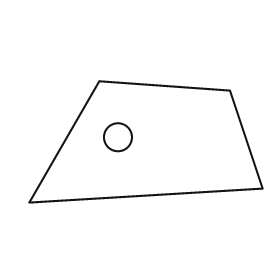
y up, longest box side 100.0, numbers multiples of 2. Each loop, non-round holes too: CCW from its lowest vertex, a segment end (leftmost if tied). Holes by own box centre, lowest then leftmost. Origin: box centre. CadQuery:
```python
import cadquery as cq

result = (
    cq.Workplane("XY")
    .moveTo(-50.0, -26.0)
    .lineTo(50.0, -20.0)
    .lineTo(36.0, 22.0)
    .lineTo(-20.0, 26.0)
    .close()
    .moveTo(-12.0, 2.0)
    .circle(6.0)
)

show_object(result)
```